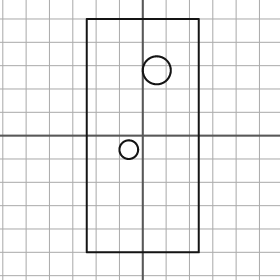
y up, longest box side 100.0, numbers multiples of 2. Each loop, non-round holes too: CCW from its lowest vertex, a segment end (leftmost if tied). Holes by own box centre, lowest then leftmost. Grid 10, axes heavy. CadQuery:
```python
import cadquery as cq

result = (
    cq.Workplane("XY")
    .moveTo(-24.0, -50.0)
    .lineTo(24.0, -50.0)
    .lineTo(24.0, 50.0)
    .lineTo(-24.0, 50.0)
    .close()
    .moveTo(-6.0, -6.0)
    .circle(4.0)
    .moveTo(6.0, 28.0)
    .circle(6.0)
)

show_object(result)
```